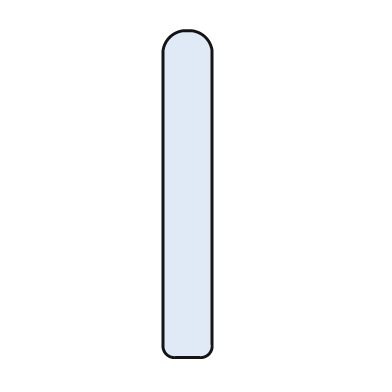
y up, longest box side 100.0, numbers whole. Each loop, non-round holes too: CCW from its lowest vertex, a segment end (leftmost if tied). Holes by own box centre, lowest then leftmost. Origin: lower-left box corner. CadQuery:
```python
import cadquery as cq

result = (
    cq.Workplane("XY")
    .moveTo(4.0, 0.0)
    .lineTo(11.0, 0.0)
    .threePointArc((14.0, 1.0), (15.0, 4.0))
    .lineTo(15.0, 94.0)
    .threePointArc((13.0, 98.0), (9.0, 100.0))
    .lineTo(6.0, 100.0)
    .threePointArc((2.0, 98.0), (0.0, 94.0))
    .lineTo(0.0, 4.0)
    .threePointArc((1.0, 1.0), (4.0, 0.0))
    .close()
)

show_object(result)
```